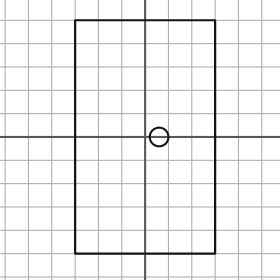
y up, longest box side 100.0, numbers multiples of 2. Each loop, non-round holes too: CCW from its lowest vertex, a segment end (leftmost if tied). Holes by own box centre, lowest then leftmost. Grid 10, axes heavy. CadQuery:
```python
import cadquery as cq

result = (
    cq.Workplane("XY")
    .moveTo(-30.0, -50.0)
    .lineTo(30.0, -50.0)
    .lineTo(30.0, 50.0)
    .lineTo(-30.0, 50.0)
    .close()
    .moveTo(6.0, 0.0)
    .circle(4.0)
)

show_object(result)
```